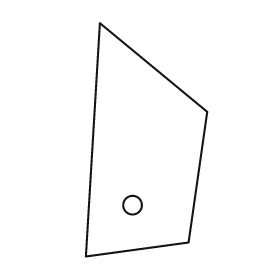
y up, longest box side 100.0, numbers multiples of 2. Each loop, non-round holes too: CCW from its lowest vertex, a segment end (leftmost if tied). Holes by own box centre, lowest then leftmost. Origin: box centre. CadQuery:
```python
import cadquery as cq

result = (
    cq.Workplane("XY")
    .moveTo(-26.0, -50.0)
    .lineTo(18.0, -44.0)
    .lineTo(26.0, 12.0)
    .lineTo(-20.0, 50.0)
    .close()
    .moveTo(-6.0, -28.0)
    .circle(4.0)
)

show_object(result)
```